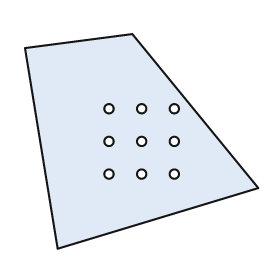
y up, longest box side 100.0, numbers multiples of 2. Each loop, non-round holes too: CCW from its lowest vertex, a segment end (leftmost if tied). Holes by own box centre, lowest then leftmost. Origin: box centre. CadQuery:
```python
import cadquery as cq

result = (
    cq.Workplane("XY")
    .moveTo(-36.0, -46.0)
    .lineTo(50.0, -20.0)
    .lineTo(-4.0, 46.0)
    .lineTo(-50.0, 40.0)
    .close()
    .moveTo(-14.0, -14.0)
    .circle(2.0)
    .moveTo(0.0, -14.0)
    .circle(2.0)
    .moveTo(14.0, -14.0)
    .circle(2.0)
    .moveTo(-14.0, 0.0)
    .circle(2.0)
    .moveTo(0.0, 0.0)
    .circle(2.0)
    .moveTo(14.0, 0.0)
    .circle(2.0)
    .moveTo(-14.0, 14.0)
    .circle(2.0)
    .moveTo(0.0, 14.0)
    .circle(2.0)
    .moveTo(14.0, 14.0)
    .circle(2.0)
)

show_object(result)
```